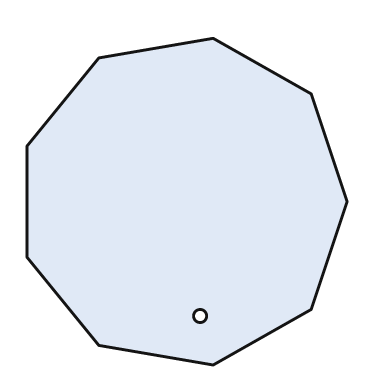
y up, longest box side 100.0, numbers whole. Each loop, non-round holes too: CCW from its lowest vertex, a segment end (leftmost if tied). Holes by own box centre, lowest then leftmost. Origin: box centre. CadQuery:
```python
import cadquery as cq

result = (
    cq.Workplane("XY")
    .moveTo(8.0, -50.0)
    .lineTo(38.0, -33.0)
    .lineTo(49.0, 0.0)
    .lineTo(38.0, 33.0)
    .lineTo(8.0, 50.0)
    .lineTo(-27.0, 44.0)
    .lineTo(-49.0, 17.0)
    .lineTo(-49.0, -17.0)
    .lineTo(-27.0, -44.0)
    .close()
    .moveTo(4.0, -35.0)
    .circle(2.0)
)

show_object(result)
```